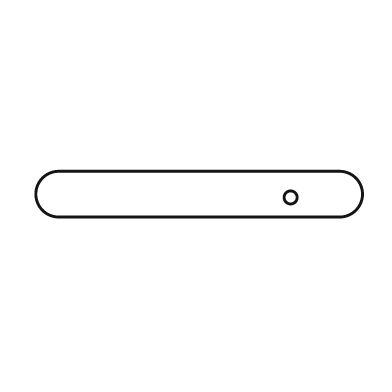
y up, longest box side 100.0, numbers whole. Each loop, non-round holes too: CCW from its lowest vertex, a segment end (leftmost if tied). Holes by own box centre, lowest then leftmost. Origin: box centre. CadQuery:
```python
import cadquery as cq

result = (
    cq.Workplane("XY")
    .moveTo(-43.0, -7.0)
    .lineTo(43.0, -7.0)
    .threePointArc((50.0, 0.0), (43.0, 7.0))
    .lineTo(-43.0, 7.0)
    .threePointArc((-50.0, 0.0), (-43.0, -7.0))
    .close()
    .moveTo(28.0, -1.0)
    .circle(2.0)
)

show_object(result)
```